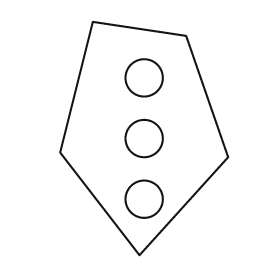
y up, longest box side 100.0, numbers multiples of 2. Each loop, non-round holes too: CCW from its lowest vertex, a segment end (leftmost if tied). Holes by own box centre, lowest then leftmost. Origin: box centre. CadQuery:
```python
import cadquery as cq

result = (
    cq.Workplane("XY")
    .moveTo(-2.0, -50.0)
    .lineTo(36.0, -8.0)
    .lineTo(18.0, 44.0)
    .lineTo(-22.0, 50.0)
    .lineTo(-36.0, -6.0)
    .close()
    .moveTo(0.0, -26.0)
    .circle(8.0)
    .moveTo(0.0, 0.0)
    .circle(8.0)
    .moveTo(0.0, 26.0)
    .circle(8.0)
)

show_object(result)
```